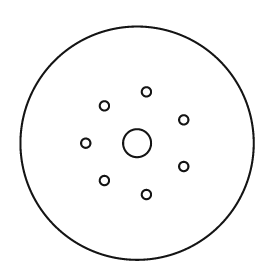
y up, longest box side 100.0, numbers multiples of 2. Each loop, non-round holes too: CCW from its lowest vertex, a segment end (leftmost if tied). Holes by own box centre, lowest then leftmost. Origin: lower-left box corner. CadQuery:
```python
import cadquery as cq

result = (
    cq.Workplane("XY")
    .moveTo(50.0, 50.0)
    .circle(50.0)
    .moveTo(54.0, 28.0)
    .circle(2.0)
    .moveTo(36.0, 34.0)
    .circle(2.0)
    .moveTo(70.0, 40.0)
    .circle(2.0)
    .moveTo(28.0, 50.0)
    .circle(2.0)
    .moveTo(50.0, 50.0)
    .circle(6.0)
    .moveTo(70.0, 60.0)
    .circle(2.0)
    .moveTo(36.0, 66.0)
    .circle(2.0)
    .moveTo(54.0, 72.0)
    .circle(2.0)
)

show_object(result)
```